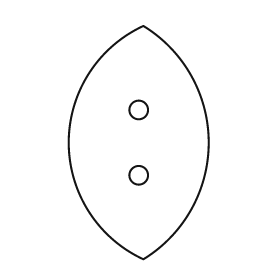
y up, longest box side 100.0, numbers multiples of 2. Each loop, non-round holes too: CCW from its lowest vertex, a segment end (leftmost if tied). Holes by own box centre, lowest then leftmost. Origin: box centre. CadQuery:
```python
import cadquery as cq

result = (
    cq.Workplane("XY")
    .moveTo(2.0, -50.0)
    .threePointArc((30.0, 0.0), (2.0, 50.0))
    .threePointArc((-30.0, 0.0), (2.0, -50.0))
    .close()
    .moveTo(0.0, -14.0)
    .circle(4.0)
    .moveTo(0.0, 14.0)
    .circle(4.0)
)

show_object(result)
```